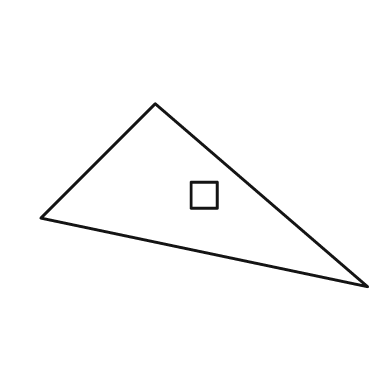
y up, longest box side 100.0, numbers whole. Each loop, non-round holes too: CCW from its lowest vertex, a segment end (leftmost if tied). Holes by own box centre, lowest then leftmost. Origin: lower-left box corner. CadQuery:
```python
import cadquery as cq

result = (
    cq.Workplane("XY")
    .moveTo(100.0, 0.0)
    .lineTo(35.0, 56.0)
    .lineTo(0.0, 21.0)
    .close()
    .moveTo(46.0, 24.0)
    .lineTo(54.0, 24.0)
    .lineTo(54.0, 32.0)
    .lineTo(46.0, 32.0)
    .close()
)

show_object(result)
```